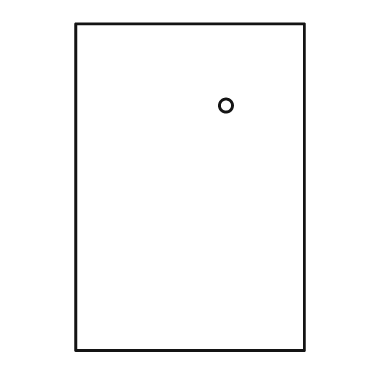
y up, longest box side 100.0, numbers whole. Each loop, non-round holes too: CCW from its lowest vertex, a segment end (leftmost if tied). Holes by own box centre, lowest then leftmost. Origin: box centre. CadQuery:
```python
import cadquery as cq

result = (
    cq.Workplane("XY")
    .moveTo(-35.0, -50.0)
    .lineTo(35.0, -50.0)
    .lineTo(35.0, 50.0)
    .lineTo(-35.0, 50.0)
    .close()
    .moveTo(11.0, 25.0)
    .circle(2.0)
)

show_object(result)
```